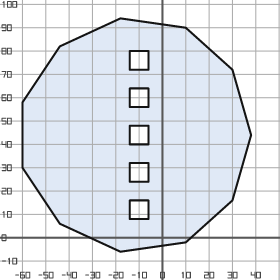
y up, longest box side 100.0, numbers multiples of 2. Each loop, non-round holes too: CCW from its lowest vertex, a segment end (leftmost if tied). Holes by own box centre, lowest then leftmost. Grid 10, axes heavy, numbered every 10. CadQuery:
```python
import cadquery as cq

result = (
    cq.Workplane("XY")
    .moveTo(-18.0, -6.0)
    .lineTo(10.0, -2.0)
    .lineTo(30.0, 16.0)
    .lineTo(38.0, 44.0)
    .lineTo(30.0, 72.0)
    .lineTo(10.0, 90.0)
    .lineTo(-18.0, 94.0)
    .lineTo(-44.0, 82.0)
    .lineTo(-60.0, 58.0)
    .lineTo(-60.0, 30.0)
    .lineTo(-44.0, 6.0)
    .close()
    .moveTo(-14.0, 8.0)
    .lineTo(-6.0, 8.0)
    .lineTo(-6.0, 16.0)
    .lineTo(-14.0, 16.0)
    .close()
    .moveTo(-14.0, 24.0)
    .lineTo(-6.0, 24.0)
    .lineTo(-6.0, 32.0)
    .lineTo(-14.0, 32.0)
    .close()
    .moveTo(-14.0, 40.0)
    .lineTo(-6.0, 40.0)
    .lineTo(-6.0, 48.0)
    .lineTo(-14.0, 48.0)
    .close()
    .moveTo(-14.0, 56.0)
    .lineTo(-6.0, 56.0)
    .lineTo(-6.0, 64.0)
    .lineTo(-14.0, 64.0)
    .close()
    .moveTo(-14.0, 72.0)
    .lineTo(-6.0, 72.0)
    .lineTo(-6.0, 80.0)
    .lineTo(-14.0, 80.0)
    .close()
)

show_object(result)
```